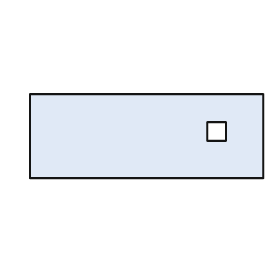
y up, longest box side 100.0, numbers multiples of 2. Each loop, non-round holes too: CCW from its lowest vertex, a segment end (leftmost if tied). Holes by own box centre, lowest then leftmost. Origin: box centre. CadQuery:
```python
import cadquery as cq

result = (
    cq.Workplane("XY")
    .moveTo(-50.0, -18.0)
    .lineTo(50.0, -18.0)
    .lineTo(50.0, 18.0)
    .lineTo(-50.0, 18.0)
    .close()
    .moveTo(26.0, -2.0)
    .lineTo(34.0, -2.0)
    .lineTo(34.0, 6.0)
    .lineTo(26.0, 6.0)
    .close()
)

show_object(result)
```